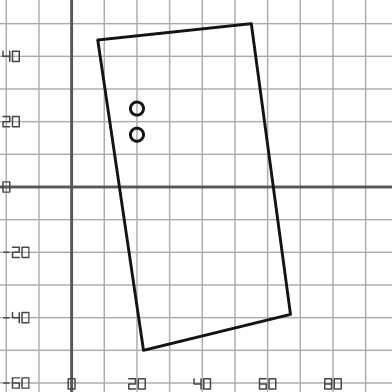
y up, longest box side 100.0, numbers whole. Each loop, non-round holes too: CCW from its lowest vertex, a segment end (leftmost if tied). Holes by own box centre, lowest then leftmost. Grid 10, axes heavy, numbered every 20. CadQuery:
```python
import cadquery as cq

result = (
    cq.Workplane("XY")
    .moveTo(22.0, -50.0)
    .lineTo(67.0, -39.0)
    .lineTo(55.0, 50.0)
    .lineTo(8.0, 45.0)
    .close()
    .moveTo(20.0, 16.0)
    .circle(2.0)
    .moveTo(20.0, 24.0)
    .circle(2.0)
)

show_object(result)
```